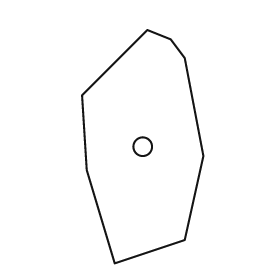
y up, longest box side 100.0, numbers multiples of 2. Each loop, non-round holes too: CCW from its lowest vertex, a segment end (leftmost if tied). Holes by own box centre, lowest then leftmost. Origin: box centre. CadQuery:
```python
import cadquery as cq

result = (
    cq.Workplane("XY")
    .moveTo(-12.0, -50.0)
    .lineTo(18.0, -40.0)
    .lineTo(26.0, -4.0)
    .lineTo(18.0, 38.0)
    .lineTo(12.0, 46.0)
    .lineTo(2.0, 50.0)
    .lineTo(-26.0, 22.0)
    .lineTo(-24.0, -10.0)
    .close()
    .moveTo(0.0, 0.0)
    .circle(4.0)
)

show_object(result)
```